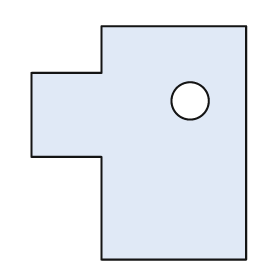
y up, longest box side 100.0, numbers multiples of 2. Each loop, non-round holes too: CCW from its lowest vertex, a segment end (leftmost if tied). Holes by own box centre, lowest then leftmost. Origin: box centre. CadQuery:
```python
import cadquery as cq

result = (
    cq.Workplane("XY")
    .moveTo(-16.0, -50.0)
    .lineTo(46.0, -50.0)
    .lineTo(46.0, 50.0)
    .lineTo(-16.0, 50.0)
    .lineTo(-16.0, 30.0)
    .lineTo(-46.0, 30.0)
    .lineTo(-46.0, -6.0)
    .lineTo(-16.0, -6.0)
    .close()
    .moveTo(22.0, 18.0)
    .circle(8.0)
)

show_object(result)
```